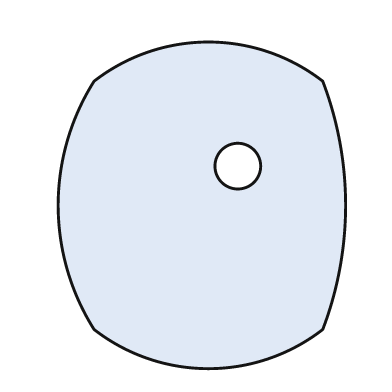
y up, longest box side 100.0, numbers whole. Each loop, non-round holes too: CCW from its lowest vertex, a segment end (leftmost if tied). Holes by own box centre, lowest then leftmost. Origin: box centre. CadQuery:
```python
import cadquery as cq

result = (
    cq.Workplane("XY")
    .moveTo(-33.0, -38.0)
    .threePointArc((2.0, -50.0), (37.0, -38.0))
    .threePointArc((44.0, 0.0), (37.0, 38.0))
    .threePointArc((2.0, 50.0), (-33.0, 38.0))
    .threePointArc((-44.0, 0.0), (-33.0, -38.0))
    .close()
    .moveTo(11.0, 12.0)
    .circle(7.0)
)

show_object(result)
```